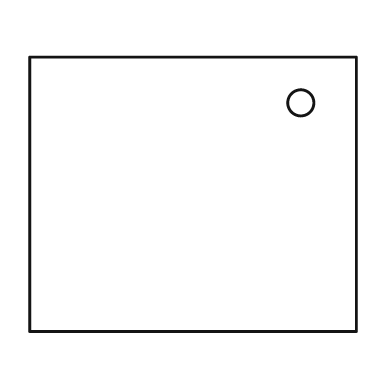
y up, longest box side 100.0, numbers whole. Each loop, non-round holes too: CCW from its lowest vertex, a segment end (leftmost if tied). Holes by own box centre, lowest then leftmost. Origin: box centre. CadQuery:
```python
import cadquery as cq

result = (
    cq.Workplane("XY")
    .moveTo(-50.0, -42.0)
    .lineTo(50.0, -42.0)
    .lineTo(50.0, 42.0)
    .lineTo(-50.0, 42.0)
    .close()
    .moveTo(33.0, 28.0)
    .circle(4.0)
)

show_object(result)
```